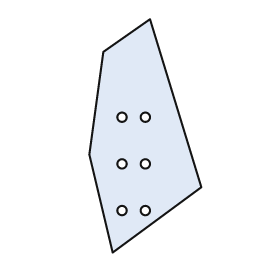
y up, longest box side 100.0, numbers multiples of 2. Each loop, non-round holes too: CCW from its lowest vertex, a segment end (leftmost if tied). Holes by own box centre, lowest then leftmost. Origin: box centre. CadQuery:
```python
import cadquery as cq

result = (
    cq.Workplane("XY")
    .moveTo(-14.0, -50.0)
    .lineTo(24.0, -22.0)
    .lineTo(2.0, 50.0)
    .lineTo(-18.0, 36.0)
    .lineTo(-24.0, -8.0)
    .close()
    .moveTo(-10.0, -32.0)
    .circle(2.0)
    .moveTo(0.0, -32.0)
    .circle(2.0)
    .moveTo(-10.0, -12.0)
    .circle(2.0)
    .moveTo(0.0, -12.0)
    .circle(2.0)
    .moveTo(-10.0, 8.0)
    .circle(2.0)
    .moveTo(0.0, 8.0)
    .circle(2.0)
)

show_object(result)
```